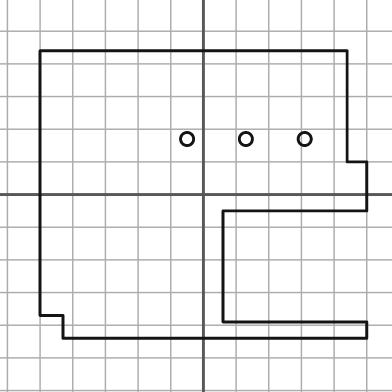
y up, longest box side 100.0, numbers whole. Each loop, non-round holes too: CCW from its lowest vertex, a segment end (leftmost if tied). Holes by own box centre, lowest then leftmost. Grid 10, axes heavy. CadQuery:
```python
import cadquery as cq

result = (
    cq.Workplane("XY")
    .moveTo(-43.0, -44.0)
    .lineTo(50.0, -44.0)
    .lineTo(50.0, -39.0)
    .lineTo(6.0, -39.0)
    .lineTo(6.0, -5.0)
    .lineTo(50.0, -5.0)
    .lineTo(50.0, 10.0)
    .lineTo(44.0, 10.0)
    .lineTo(44.0, 44.0)
    .lineTo(-50.0, 44.0)
    .lineTo(-50.0, -37.0)
    .lineTo(-43.0, -37.0)
    .close()
    .moveTo(-5.0, 17.0)
    .circle(2.0)
    .moveTo(13.0, 17.0)
    .circle(2.0)
    .moveTo(31.0, 17.0)
    .circle(2.0)
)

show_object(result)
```